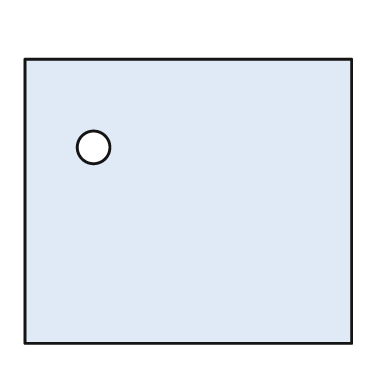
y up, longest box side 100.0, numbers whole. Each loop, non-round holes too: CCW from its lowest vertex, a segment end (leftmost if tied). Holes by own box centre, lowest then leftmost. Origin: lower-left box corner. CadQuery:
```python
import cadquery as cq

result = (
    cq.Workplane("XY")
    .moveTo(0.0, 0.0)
    .lineTo(100.0, 0.0)
    .lineTo(100.0, 87.0)
    .lineTo(0.0, 87.0)
    .close()
    .moveTo(21.0, 60.0)
    .circle(5.0)
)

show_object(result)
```